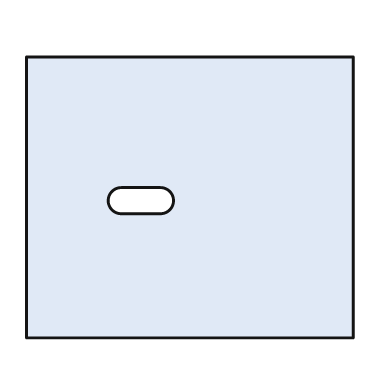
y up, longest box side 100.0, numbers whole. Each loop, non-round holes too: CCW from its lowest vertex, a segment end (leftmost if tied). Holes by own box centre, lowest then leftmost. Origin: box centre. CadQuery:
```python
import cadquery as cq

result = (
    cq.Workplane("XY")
    .moveTo(-50.0, -43.0)
    .lineTo(50.0, -43.0)
    .lineTo(50.0, 43.0)
    .lineTo(-50.0, 43.0)
    .close()
    .moveTo(-21.0, -5.0)
    .lineTo(-9.0, -5.0)
    .threePointArc((-5.0, -1.0), (-9.0, 3.0))
    .lineTo(-21.0, 3.0)
    .threePointArc((-25.0, -1.0), (-21.0, -5.0))
    .close()
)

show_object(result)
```